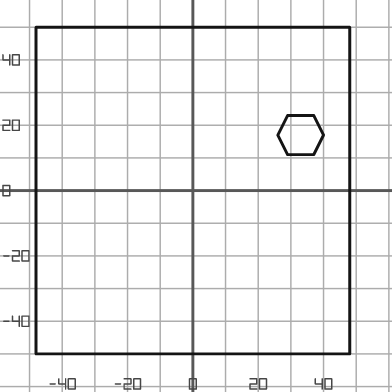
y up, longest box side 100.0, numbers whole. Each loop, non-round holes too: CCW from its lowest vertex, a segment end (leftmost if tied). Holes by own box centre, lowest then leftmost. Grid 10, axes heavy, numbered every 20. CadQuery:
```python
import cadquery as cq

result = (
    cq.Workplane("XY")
    .moveTo(-48.0, -50.0)
    .lineTo(48.0, -50.0)
    .lineTo(48.0, 50.0)
    .lineTo(-48.0, 50.0)
    .close()
    .moveTo(29.0, 11.0)
    .lineTo(37.0, 11.0)
    .lineTo(40.0, 17.0)
    .lineTo(37.0, 23.0)
    .lineTo(29.0, 23.0)
    .lineTo(26.0, 17.0)
    .close()
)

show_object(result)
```